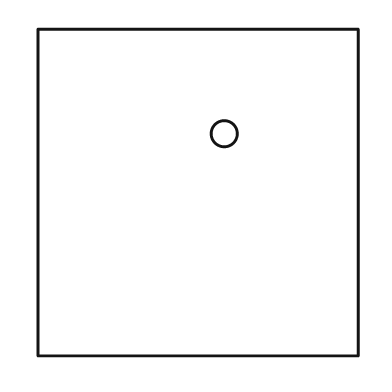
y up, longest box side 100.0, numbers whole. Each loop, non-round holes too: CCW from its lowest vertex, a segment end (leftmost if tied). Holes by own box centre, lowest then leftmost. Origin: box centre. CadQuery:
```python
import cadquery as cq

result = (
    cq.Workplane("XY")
    .moveTo(-49.0, -50.0)
    .lineTo(49.0, -50.0)
    .lineTo(49.0, 50.0)
    .lineTo(-49.0, 50.0)
    .close()
    .moveTo(8.0, 18.0)
    .circle(4.0)
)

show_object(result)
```